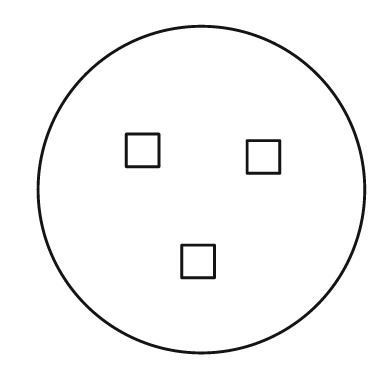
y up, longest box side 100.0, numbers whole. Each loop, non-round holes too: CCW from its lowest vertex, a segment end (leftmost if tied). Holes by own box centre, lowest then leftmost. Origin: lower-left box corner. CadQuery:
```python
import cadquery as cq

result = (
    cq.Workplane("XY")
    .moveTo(50.0, 50.0)
    .circle(50.0)
    .moveTo(44.0, 23.0)
    .lineTo(54.0, 23.0)
    .lineTo(54.0, 33.0)
    .lineTo(44.0, 33.0)
    .close()
    .moveTo(64.0, 55.0)
    .lineTo(74.0, 55.0)
    .lineTo(74.0, 65.0)
    .lineTo(64.0, 65.0)
    .close()
    .moveTo(27.0, 57.0)
    .lineTo(37.0, 57.0)
    .lineTo(37.0, 67.0)
    .lineTo(27.0, 67.0)
    .close()
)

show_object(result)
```